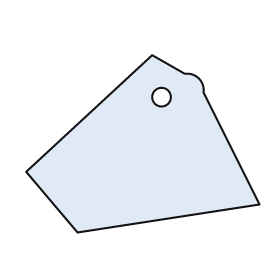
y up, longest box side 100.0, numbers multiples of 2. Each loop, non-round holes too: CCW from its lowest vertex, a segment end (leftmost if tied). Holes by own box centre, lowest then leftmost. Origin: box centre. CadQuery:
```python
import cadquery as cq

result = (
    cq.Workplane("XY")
    .moveTo(-28.0, -38.0)
    .lineTo(50.0, -26.0)
    .lineTo(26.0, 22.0)
    .threePointArc((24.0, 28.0), (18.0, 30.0))
    .lineTo(4.0, 38.0)
    .lineTo(-50.0, -12.0)
    .close()
    .moveTo(8.0, 20.0)
    .circle(4.0)
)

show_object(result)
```